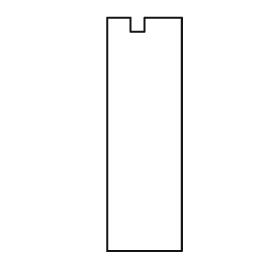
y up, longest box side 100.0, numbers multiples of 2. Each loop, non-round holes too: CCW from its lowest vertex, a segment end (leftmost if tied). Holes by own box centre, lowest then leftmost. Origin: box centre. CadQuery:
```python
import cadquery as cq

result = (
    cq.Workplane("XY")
    .moveTo(-16.0, -50.0)
    .lineTo(16.0, -50.0)
    .lineTo(16.0, 50.0)
    .lineTo(0.0, 50.0)
    .lineTo(0.0, 44.0)
    .lineTo(-6.0, 44.0)
    .lineTo(-6.0, 50.0)
    .lineTo(-16.0, 50.0)
    .close()
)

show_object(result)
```